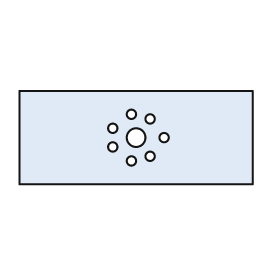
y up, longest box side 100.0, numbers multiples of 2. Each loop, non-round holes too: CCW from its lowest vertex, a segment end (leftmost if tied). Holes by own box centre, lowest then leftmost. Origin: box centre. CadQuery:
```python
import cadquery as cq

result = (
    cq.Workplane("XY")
    .moveTo(-50.0, -20.0)
    .lineTo(50.0, -20.0)
    .lineTo(50.0, 20.0)
    .lineTo(-50.0, 20.0)
    .close()
    .moveTo(-2.0, -10.0)
    .circle(2.0)
    .moveTo(6.0, -8.0)
    .circle(2.0)
    .moveTo(-10.0, -4.0)
    .circle(2.0)
    .moveTo(0.0, 0.0)
    .circle(4.0)
    .moveTo(12.0, 0.0)
    .circle(2.0)
    .moveTo(-10.0, 4.0)
    .circle(2.0)
    .moveTo(6.0, 8.0)
    .circle(2.0)
    .moveTo(-2.0, 10.0)
    .circle(2.0)
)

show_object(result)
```